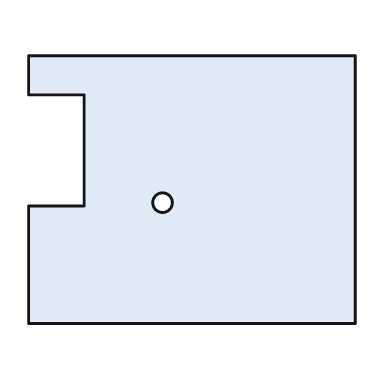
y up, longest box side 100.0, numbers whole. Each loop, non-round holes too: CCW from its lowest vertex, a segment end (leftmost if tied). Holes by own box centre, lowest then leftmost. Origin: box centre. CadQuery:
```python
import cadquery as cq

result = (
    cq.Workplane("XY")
    .moveTo(-50.0, -41.0)
    .lineTo(50.0, -41.0)
    .lineTo(50.0, 41.0)
    .lineTo(-50.0, 41.0)
    .lineTo(-50.0, 29.0)
    .lineTo(-33.0, 29.0)
    .lineTo(-33.0, -5.0)
    .lineTo(-50.0, -5.0)
    .close()
    .moveTo(-9.0, -4.0)
    .circle(3.0)
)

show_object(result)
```